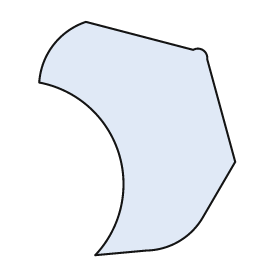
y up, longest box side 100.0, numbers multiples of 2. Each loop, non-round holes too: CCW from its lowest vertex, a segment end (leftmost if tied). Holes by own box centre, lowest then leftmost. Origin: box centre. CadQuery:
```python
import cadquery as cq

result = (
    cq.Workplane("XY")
    .moveTo(-18.0, -50.0)
    .lineTo(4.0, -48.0)
    .threePointArc((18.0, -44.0), (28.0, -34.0))
    .lineTo(42.0, -10.0)
    .lineTo(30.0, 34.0)
    .threePointArc((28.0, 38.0), (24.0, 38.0))
    .lineTo(-22.0, 50.0)
    .threePointArc((-36.0, 40.0), (-42.0, 24.0))
    .threePointArc((-8.0, -6.0), (-18.0, -50.0))
    .close()
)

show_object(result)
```